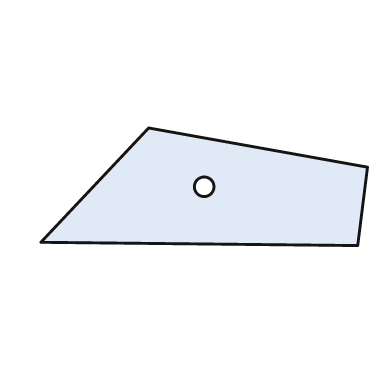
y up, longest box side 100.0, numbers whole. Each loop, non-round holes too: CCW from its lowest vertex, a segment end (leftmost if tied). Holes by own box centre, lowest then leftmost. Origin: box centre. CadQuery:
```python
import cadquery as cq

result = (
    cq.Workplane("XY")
    .moveTo(47.0, -18.0)
    .lineTo(50.0, 6.0)
    .lineTo(-17.0, 18.0)
    .lineTo(-50.0, -17.0)
    .close()
    .moveTo(0.0, 0.0)
    .circle(3.0)
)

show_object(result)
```